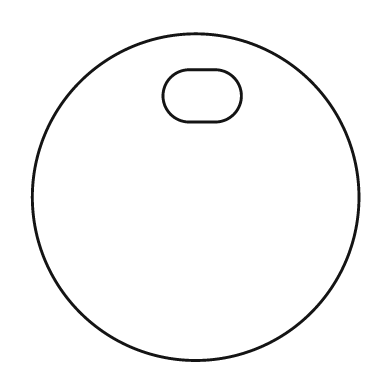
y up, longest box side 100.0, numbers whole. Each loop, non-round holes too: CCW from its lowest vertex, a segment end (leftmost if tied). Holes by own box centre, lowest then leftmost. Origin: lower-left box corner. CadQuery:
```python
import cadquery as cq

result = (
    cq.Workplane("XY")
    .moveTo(50.0, 50.0)
    .circle(50.0)
    .moveTo(48.0, 73.0)
    .lineTo(56.0, 73.0)
    .threePointArc((64.0, 81.0), (56.0, 89.0))
    .lineTo(48.0, 89.0)
    .threePointArc((40.0, 81.0), (48.0, 73.0))
    .close()
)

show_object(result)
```